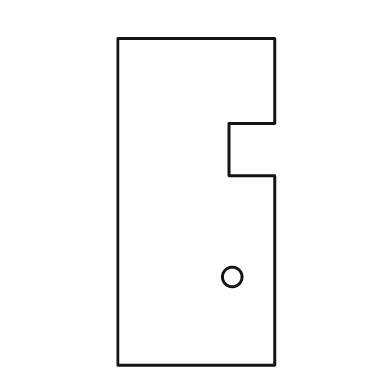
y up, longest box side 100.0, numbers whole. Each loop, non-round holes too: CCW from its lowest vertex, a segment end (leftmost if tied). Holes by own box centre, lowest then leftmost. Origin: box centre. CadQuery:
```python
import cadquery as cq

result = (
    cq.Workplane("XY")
    .moveTo(-24.0, -50.0)
    .lineTo(24.0, -50.0)
    .lineTo(24.0, 8.0)
    .lineTo(10.0, 8.0)
    .lineTo(10.0, 24.0)
    .lineTo(24.0, 24.0)
    .lineTo(24.0, 50.0)
    .lineTo(-24.0, 50.0)
    .close()
    .moveTo(11.0, -23.0)
    .circle(3.0)
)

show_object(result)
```